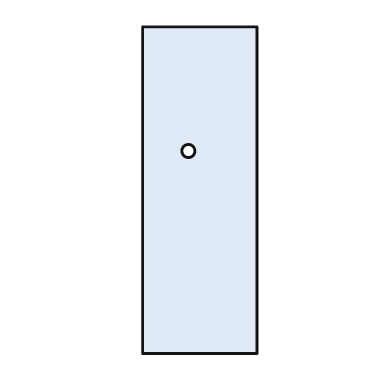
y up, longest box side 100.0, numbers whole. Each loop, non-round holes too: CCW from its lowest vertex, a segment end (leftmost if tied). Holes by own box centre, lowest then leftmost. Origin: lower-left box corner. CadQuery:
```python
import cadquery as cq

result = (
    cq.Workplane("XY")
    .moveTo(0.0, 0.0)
    .lineTo(35.0, 0.0)
    .lineTo(35.0, 100.0)
    .lineTo(0.0, 100.0)
    .close()
    .moveTo(14.0, 62.0)
    .circle(2.0)
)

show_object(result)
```